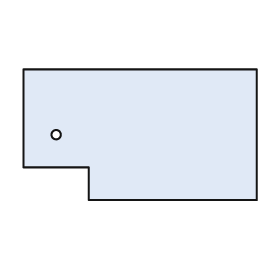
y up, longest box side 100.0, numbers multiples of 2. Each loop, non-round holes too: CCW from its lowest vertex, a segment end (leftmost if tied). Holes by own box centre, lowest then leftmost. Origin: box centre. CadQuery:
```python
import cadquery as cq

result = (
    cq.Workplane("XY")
    .moveTo(-22.0, -28.0)
    .lineTo(50.0, -28.0)
    .lineTo(50.0, 28.0)
    .lineTo(-50.0, 28.0)
    .lineTo(-50.0, -14.0)
    .lineTo(-22.0, -14.0)
    .close()
    .moveTo(-36.0, 0.0)
    .circle(2.0)
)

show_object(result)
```